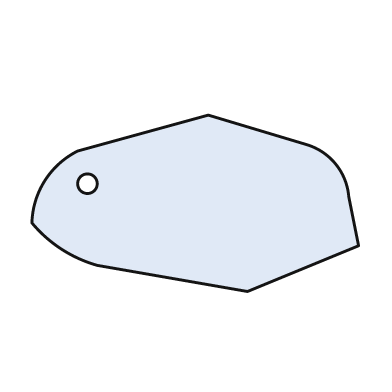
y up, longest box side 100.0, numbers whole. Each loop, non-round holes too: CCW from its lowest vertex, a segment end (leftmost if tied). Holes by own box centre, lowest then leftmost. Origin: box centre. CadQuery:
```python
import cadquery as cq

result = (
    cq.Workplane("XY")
    .moveTo(16.0, -27.0)
    .lineTo(50.0, -13.0)
    .lineTo(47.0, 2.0)
    .threePointArc((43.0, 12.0), (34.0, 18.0))
    .lineTo(4.0, 27.0)
    .lineTo(-36.0, 16.0)
    .threePointArc((-46.0, 7.0), (-50.0, -6.0))
    .threePointArc((-41.0, -14.0), (-30.0, -19.0))
    .close()
    .moveTo(-33.0, 6.0)
    .circle(3.0)
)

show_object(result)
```